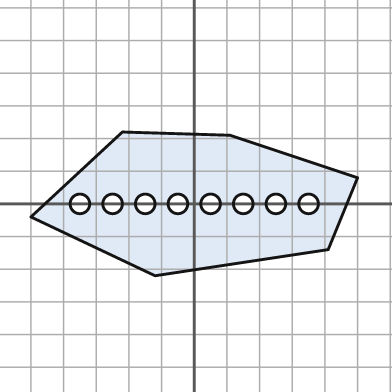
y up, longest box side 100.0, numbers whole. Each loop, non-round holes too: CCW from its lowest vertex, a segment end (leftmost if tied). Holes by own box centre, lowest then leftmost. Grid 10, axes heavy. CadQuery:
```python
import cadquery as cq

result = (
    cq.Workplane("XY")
    .moveTo(-12.0, -22.0)
    .lineTo(41.0, -14.0)
    .lineTo(50.0, 8.0)
    .lineTo(11.0, 21.0)
    .lineTo(-22.0, 22.0)
    .lineTo(-50.0, -4.0)
    .close()
    .moveTo(-35.0, 0.0)
    .circle(3.0)
    .moveTo(-25.0, 0.0)
    .circle(3.0)
    .moveTo(-15.0, 0.0)
    .circle(3.0)
    .moveTo(-5.0, 0.0)
    .circle(3.0)
    .moveTo(5.0, 0.0)
    .circle(3.0)
    .moveTo(15.0, 0.0)
    .circle(3.0)
    .moveTo(25.0, 0.0)
    .circle(3.0)
    .moveTo(35.0, 0.0)
    .circle(3.0)
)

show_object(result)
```